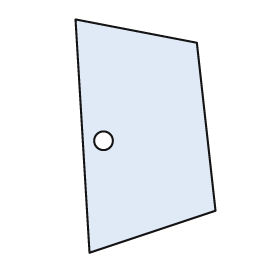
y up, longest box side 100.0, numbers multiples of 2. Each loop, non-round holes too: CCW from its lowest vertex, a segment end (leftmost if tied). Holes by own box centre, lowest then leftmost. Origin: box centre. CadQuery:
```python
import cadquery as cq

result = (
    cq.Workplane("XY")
    .moveTo(-24.0, -50.0)
    .lineTo(30.0, -32.0)
    .lineTo(22.0, 40.0)
    .lineTo(-30.0, 50.0)
    .close()
    .moveTo(-18.0, -2.0)
    .circle(4.0)
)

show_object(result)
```